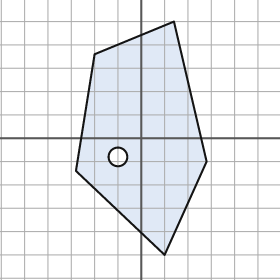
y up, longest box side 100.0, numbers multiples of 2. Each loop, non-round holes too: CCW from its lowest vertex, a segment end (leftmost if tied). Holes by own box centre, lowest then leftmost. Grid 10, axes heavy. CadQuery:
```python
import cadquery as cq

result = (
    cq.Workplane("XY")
    .moveTo(10.0, -50.0)
    .lineTo(28.0, -10.0)
    .lineTo(14.0, 50.0)
    .lineTo(-20.0, 36.0)
    .lineTo(-28.0, -14.0)
    .close()
    .moveTo(-10.0, -8.0)
    .circle(4.0)
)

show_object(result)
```